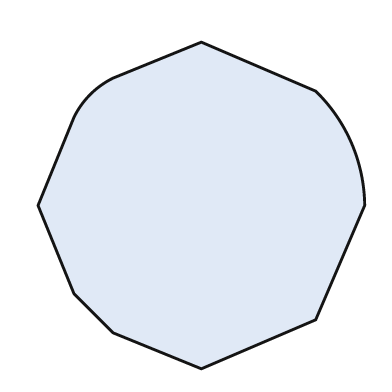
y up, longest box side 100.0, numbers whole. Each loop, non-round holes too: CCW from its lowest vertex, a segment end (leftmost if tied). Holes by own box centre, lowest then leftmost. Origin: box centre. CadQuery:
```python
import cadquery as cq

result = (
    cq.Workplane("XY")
    .moveTo(0.0, -50.0)
    .lineTo(35.0, -35.0)
    .lineTo(50.0, 0.0)
    .threePointArc((46.0, 19.0), (35.0, 35.0))
    .lineTo(0.0, 50.0)
    .lineTo(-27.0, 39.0)
    .threePointArc((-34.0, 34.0), (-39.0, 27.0))
    .lineTo(-50.0, 0.0)
    .lineTo(-39.0, -27.0)
    .lineTo(-27.0, -39.0)
    .close()
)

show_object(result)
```